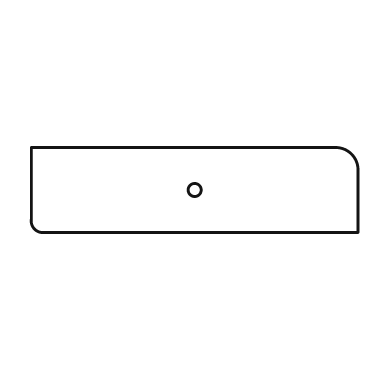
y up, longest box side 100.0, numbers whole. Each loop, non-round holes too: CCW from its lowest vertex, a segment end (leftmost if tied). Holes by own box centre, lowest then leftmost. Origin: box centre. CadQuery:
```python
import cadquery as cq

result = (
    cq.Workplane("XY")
    .moveTo(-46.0, -13.0)
    .lineTo(50.0, -13.0)
    .lineTo(50.0, 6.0)
    .threePointArc((48.0, 11.0), (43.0, 13.0))
    .lineTo(-50.0, 13.0)
    .lineTo(-50.0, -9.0)
    .threePointArc((-49.0, -12.0), (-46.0, -13.0))
    .close()
    .moveTo(0.0, 0.0)
    .circle(2.0)
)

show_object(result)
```